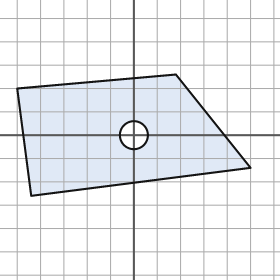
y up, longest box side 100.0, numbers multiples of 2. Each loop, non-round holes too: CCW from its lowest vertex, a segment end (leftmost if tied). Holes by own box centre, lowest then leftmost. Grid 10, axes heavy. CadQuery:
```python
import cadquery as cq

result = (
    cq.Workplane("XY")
    .moveTo(-44.0, -26.0)
    .lineTo(50.0, -14.0)
    .lineTo(18.0, 26.0)
    .lineTo(-50.0, 20.0)
    .close()
    .moveTo(0.0, 0.0)
    .circle(6.0)
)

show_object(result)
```